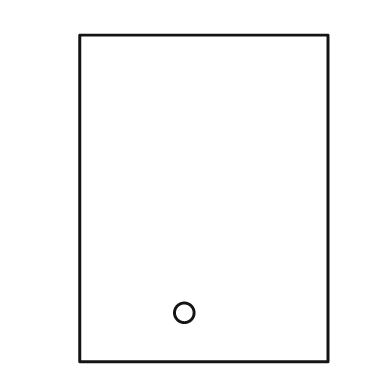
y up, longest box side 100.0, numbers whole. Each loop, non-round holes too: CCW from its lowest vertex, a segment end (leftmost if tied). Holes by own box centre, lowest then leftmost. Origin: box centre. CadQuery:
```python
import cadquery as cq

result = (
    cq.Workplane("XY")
    .moveTo(-38.0, -50.0)
    .lineTo(38.0, -50.0)
    .lineTo(38.0, 50.0)
    .lineTo(-38.0, 50.0)
    .close()
    .moveTo(-6.0, -35.0)
    .circle(3.0)
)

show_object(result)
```